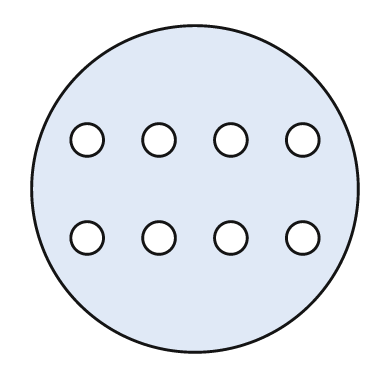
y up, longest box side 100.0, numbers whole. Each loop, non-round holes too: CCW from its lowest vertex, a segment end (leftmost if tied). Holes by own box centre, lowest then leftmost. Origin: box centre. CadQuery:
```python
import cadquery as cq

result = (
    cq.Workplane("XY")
    .moveTo(0.0, 0.0)
    .circle(50.0)
    .moveTo(-33.0, -15.0)
    .circle(5.0)
    .moveTo(-11.0, -15.0)
    .circle(5.0)
    .moveTo(11.0, -15.0)
    .circle(5.0)
    .moveTo(33.0, -15.0)
    .circle(5.0)
    .moveTo(-33.0, 15.0)
    .circle(5.0)
    .moveTo(-11.0, 15.0)
    .circle(5.0)
    .moveTo(11.0, 15.0)
    .circle(5.0)
    .moveTo(33.0, 15.0)
    .circle(5.0)
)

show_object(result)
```